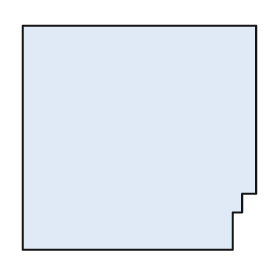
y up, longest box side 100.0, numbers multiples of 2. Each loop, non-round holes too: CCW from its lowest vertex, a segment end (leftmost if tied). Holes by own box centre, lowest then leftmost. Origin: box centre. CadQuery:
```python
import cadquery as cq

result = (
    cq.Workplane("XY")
    .moveTo(-50.0, -48.0)
    .lineTo(40.0, -48.0)
    .lineTo(40.0, -32.0)
    .lineTo(44.0, -32.0)
    .lineTo(44.0, -24.0)
    .lineTo(50.0, -24.0)
    .lineTo(50.0, 48.0)
    .lineTo(-50.0, 48.0)
    .close()
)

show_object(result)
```